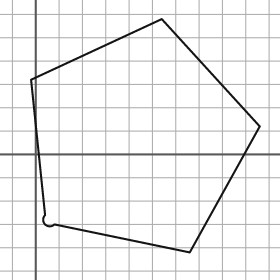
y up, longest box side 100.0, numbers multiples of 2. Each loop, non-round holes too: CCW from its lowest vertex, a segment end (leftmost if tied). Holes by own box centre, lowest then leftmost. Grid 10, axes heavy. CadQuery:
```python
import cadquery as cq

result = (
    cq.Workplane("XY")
    .moveTo(66.0, -42.0)
    .lineTo(96.0, 12.0)
    .lineTo(54.0, 58.0)
    .lineTo(-2.0, 32.0)
    .lineTo(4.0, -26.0)
    .threePointArc((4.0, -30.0), (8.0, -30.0))
    .close()
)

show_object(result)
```